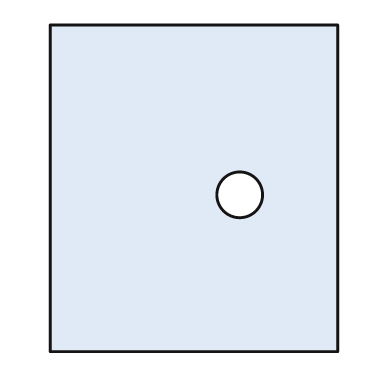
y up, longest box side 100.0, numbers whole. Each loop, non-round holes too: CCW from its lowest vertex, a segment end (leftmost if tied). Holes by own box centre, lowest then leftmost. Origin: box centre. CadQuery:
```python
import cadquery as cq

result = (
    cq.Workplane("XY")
    .moveTo(-44.0, -50.0)
    .lineTo(44.0, -50.0)
    .lineTo(44.0, 50.0)
    .lineTo(-44.0, 50.0)
    .close()
    .moveTo(14.0, -2.0)
    .circle(7.0)
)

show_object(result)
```